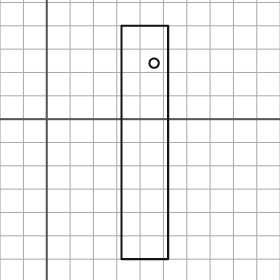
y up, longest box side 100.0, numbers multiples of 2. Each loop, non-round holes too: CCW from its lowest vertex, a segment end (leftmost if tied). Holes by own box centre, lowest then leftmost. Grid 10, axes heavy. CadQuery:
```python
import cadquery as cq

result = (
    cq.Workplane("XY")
    .moveTo(32.0, -60.0)
    .lineTo(52.0, -60.0)
    .lineTo(52.0, 40.0)
    .lineTo(32.0, 40.0)
    .close()
    .moveTo(46.0, 24.0)
    .circle(2.0)
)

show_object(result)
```